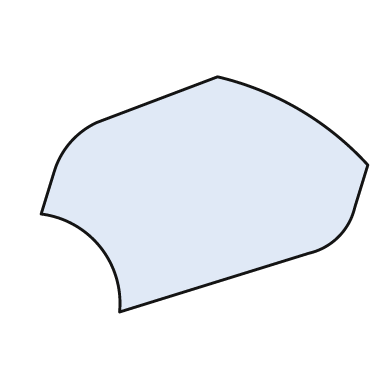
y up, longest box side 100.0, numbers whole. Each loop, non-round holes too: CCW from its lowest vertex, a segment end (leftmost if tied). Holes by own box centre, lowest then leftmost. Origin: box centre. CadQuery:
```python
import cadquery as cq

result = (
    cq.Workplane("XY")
    .moveTo(-26.0, -36.0)
    .lineTo(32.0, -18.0)
    .threePointArc((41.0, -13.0), (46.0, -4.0))
    .lineTo(50.0, 9.0)
    .threePointArc((29.0, 26.0), (4.0, 36.0))
    .lineTo(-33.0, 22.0)
    .threePointArc((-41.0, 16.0), (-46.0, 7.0))
    .lineTo(-50.0, -6.0)
    .threePointArc((-32.0, -16.0), (-26.0, -36.0))
    .close()
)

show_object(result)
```